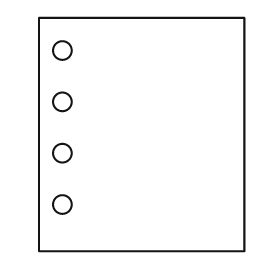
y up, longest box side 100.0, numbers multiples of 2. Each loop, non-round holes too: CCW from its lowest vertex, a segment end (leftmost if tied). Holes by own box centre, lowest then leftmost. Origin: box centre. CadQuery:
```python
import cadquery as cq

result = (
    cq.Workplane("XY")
    .moveTo(-44.0, -50.0)
    .lineTo(44.0, -50.0)
    .lineTo(44.0, 50.0)
    .lineTo(-44.0, 50.0)
    .close()
    .moveTo(-34.0, -30.0)
    .circle(4.0)
    .moveTo(-34.0, -8.0)
    .circle(4.0)
    .moveTo(-34.0, 14.0)
    .circle(4.0)
    .moveTo(-34.0, 36.0)
    .circle(4.0)
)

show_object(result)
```